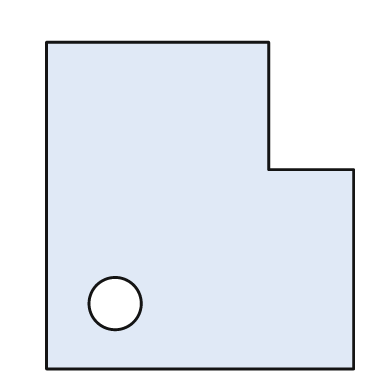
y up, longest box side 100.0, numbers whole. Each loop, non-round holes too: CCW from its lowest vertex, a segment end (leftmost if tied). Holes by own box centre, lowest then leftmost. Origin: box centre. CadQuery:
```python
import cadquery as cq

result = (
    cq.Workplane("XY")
    .moveTo(-47.0, -50.0)
    .lineTo(47.0, -50.0)
    .lineTo(47.0, 11.0)
    .lineTo(21.0, 11.0)
    .lineTo(21.0, 50.0)
    .lineTo(-47.0, 50.0)
    .close()
    .moveTo(-26.0, -30.0)
    .circle(8.0)
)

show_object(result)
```